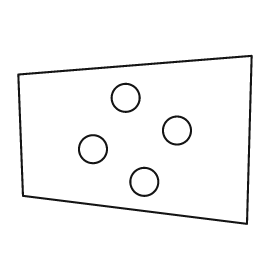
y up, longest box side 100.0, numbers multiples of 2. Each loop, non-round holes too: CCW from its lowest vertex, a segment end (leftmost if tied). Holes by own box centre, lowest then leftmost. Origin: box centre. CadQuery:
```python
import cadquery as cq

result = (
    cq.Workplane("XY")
    .moveTo(48.0, -36.0)
    .lineTo(50.0, 36.0)
    .lineTo(-50.0, 28.0)
    .lineTo(-48.0, -24.0)
    .close()
    .moveTo(4.0, -18.0)
    .circle(6.0)
    .moveTo(-18.0, -4.0)
    .circle(6.0)
    .moveTo(18.0, 4.0)
    .circle(6.0)
    .moveTo(-4.0, 18.0)
    .circle(6.0)
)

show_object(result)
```